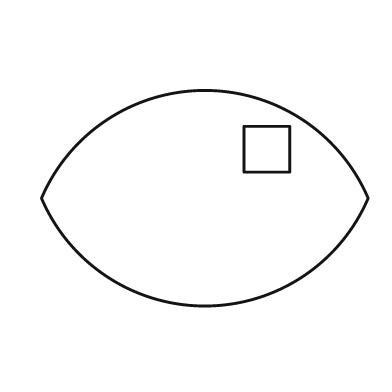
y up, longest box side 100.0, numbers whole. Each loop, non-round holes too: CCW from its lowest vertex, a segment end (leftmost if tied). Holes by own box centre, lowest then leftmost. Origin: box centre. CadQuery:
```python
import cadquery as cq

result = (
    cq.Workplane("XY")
    .moveTo(-50.0, 0.0)
    .threePointArc((0.0, -33.0), (50.0, 0.0))
    .threePointArc((0.0, 33.0), (-50.0, 0.0))
    .close()
    .moveTo(12.0, 8.0)
    .lineTo(26.0, 8.0)
    .lineTo(26.0, 22.0)
    .lineTo(12.0, 22.0)
    .close()
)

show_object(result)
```